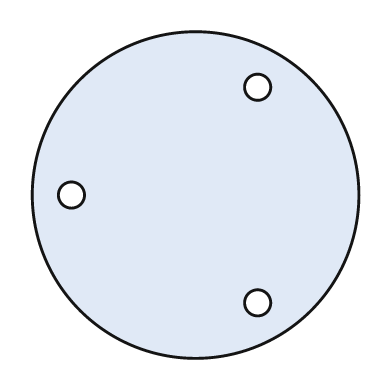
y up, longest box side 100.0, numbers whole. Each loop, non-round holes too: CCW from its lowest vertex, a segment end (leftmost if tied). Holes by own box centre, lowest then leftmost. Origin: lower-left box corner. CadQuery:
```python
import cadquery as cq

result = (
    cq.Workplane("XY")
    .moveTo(50.0, 50.0)
    .circle(50.0)
    .moveTo(69.0, 17.0)
    .circle(4.0)
    .moveTo(12.0, 50.0)
    .circle(4.0)
    .moveTo(69.0, 83.0)
    .circle(4.0)
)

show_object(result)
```